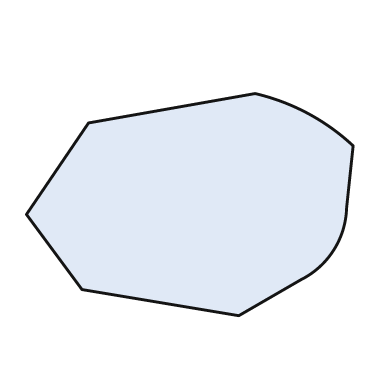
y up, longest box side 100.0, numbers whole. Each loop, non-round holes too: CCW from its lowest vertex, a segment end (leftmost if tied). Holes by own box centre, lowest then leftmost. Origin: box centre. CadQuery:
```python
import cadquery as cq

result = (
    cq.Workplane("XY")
    .moveTo(15.0, -34.0)
    .lineTo(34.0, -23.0)
    .threePointArc((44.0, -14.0), (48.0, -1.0))
    .lineTo(50.0, 18.0)
    .threePointArc((36.0, 28.0), (20.0, 34.0))
    .lineTo(-31.0, 25.0)
    .lineTo(-50.0, -3.0)
    .lineTo(-33.0, -26.0)
    .close()
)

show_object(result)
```